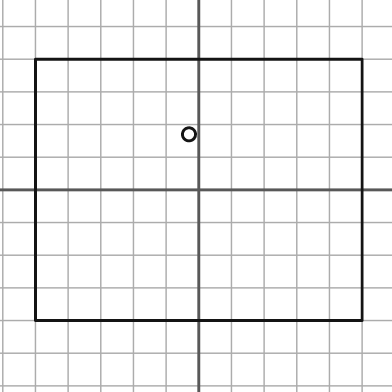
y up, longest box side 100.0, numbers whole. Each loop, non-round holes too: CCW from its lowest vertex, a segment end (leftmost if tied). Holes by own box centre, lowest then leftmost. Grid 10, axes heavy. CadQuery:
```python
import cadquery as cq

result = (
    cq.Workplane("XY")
    .moveTo(-50.0, -40.0)
    .lineTo(50.0, -40.0)
    .lineTo(50.0, 40.0)
    .lineTo(-50.0, 40.0)
    .close()
    .moveTo(-3.0, 17.0)
    .circle(2.0)
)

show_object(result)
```